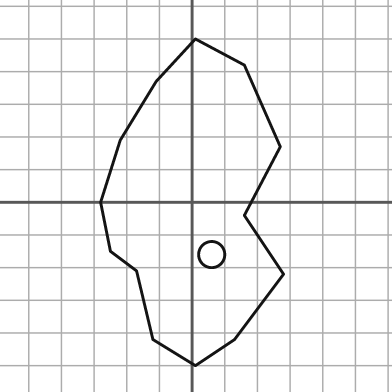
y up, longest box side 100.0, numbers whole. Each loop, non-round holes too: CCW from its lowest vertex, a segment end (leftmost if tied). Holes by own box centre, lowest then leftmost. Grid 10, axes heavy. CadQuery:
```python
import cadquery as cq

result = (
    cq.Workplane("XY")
    .moveTo(1.0, -50.0)
    .lineTo(13.0, -42.0)
    .lineTo(28.0, -22.0)
    .lineTo(16.0, -4.0)
    .lineTo(27.0, 17.0)
    .lineTo(16.0, 42.0)
    .lineTo(1.0, 50.0)
    .lineTo(-11.0, 37.0)
    .lineTo(-22.0, 19.0)
    .lineTo(-28.0, 0.0)
    .lineTo(-25.0, -15.0)
    .lineTo(-17.0, -21.0)
    .lineTo(-12.0, -42.0)
    .close()
    .moveTo(6.0, -16.0)
    .circle(4.0)
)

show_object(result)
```